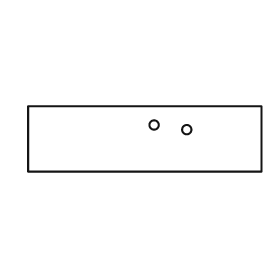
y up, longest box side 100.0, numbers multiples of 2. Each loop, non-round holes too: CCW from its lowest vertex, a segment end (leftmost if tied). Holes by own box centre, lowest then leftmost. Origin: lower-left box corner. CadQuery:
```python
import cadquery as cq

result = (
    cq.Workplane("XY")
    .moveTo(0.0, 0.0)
    .lineTo(100.0, 0.0)
    .lineTo(100.0, 28.0)
    .lineTo(0.0, 28.0)
    .close()
    .moveTo(68.0, 18.0)
    .circle(2.0)
    .moveTo(54.0, 20.0)
    .circle(2.0)
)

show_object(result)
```